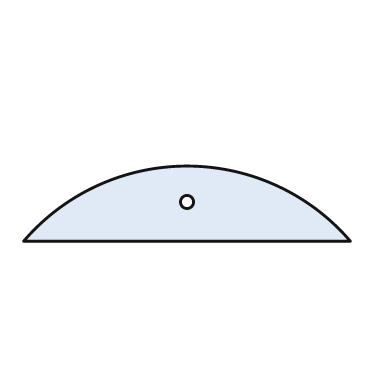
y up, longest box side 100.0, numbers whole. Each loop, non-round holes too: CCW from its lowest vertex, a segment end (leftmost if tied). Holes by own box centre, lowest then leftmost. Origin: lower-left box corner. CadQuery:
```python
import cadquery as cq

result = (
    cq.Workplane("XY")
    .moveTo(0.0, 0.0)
    .lineTo(100.0, 0.0)
    .threePointArc((50.0, 23.0), (0.0, 0.0))
    .close()
    .moveTo(50.0, 12.0)
    .circle(2.0)
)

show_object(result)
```